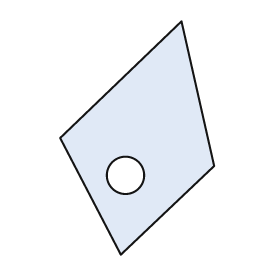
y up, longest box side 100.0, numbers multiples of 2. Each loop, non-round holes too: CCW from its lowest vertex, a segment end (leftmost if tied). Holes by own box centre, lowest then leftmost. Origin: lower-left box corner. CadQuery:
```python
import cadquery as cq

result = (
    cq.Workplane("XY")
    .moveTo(26.0, 0.0)
    .lineTo(66.0, 38.0)
    .lineTo(52.0, 100.0)
    .lineTo(0.0, 50.0)
    .close()
    .moveTo(28.0, 34.0)
    .circle(8.0)
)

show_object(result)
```